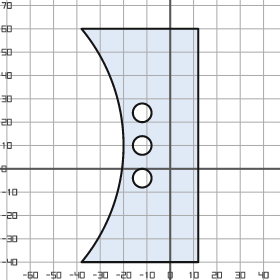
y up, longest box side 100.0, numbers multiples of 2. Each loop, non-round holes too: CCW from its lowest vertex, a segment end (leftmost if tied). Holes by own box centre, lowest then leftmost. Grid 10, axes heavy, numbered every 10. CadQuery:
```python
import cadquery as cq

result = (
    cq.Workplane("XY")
    .moveTo(-38.0, -40.0)
    .lineTo(12.0, -40.0)
    .lineTo(12.0, 60.0)
    .lineTo(-38.0, 60.0)
    .threePointArc((-20.0, 10.0), (-38.0, -40.0))
    .close()
    .moveTo(-12.0, -4.0)
    .circle(4.0)
    .moveTo(-12.0, 10.0)
    .circle(4.0)
    .moveTo(-12.0, 24.0)
    .circle(4.0)
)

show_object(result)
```